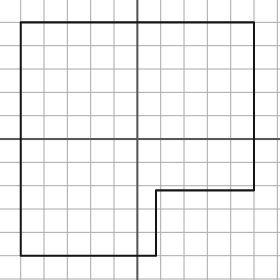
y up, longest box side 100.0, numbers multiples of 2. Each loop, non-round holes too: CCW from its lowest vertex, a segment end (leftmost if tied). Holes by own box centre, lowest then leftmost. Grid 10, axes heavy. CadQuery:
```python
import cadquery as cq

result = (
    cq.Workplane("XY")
    .moveTo(-50.0, -50.0)
    .lineTo(8.0, -50.0)
    .lineTo(8.0, -22.0)
    .lineTo(50.0, -22.0)
    .lineTo(50.0, 50.0)
    .lineTo(-50.0, 50.0)
    .close()
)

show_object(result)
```